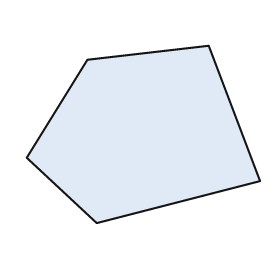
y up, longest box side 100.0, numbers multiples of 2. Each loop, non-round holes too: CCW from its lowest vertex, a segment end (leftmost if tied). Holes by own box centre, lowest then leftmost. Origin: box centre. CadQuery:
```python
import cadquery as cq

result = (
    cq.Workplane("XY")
    .moveTo(-20.0, -38.0)
    .lineTo(50.0, -20.0)
    .lineTo(28.0, 38.0)
    .lineTo(-24.0, 32.0)
    .lineTo(-50.0, -10.0)
    .close()
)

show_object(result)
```